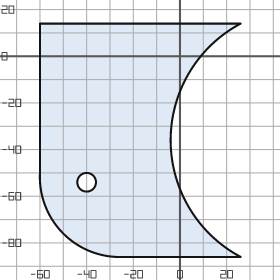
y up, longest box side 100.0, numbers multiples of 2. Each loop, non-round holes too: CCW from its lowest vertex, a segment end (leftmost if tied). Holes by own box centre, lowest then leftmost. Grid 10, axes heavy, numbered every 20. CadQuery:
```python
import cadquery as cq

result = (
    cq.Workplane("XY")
    .moveTo(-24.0, -86.0)
    .lineTo(26.0, -86.0)
    .threePointArc((-4.0, -36.0), (26.0, 14.0))
    .lineTo(-60.0, 14.0)
    .lineTo(-60.0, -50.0)
    .threePointArc((-50.0, -76.0), (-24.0, -86.0))
    .close()
    .moveTo(-40.0, -54.0)
    .circle(4.0)
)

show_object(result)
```